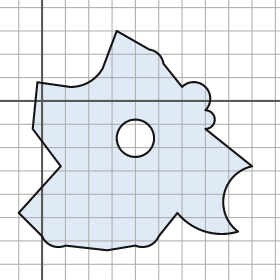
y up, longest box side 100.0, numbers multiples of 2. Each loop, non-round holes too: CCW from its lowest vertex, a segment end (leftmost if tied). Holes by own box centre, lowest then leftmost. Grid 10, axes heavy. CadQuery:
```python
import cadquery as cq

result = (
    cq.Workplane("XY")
    .moveTo(28.0, -64.0)
    .lineTo(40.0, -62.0)
    .threePointArc((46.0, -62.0), (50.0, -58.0))
    .lineTo(58.0, -48.0)
    .threePointArc((70.0, -56.0), (84.0, -56.0))
    .threePointArc((78.0, -40.0), (90.0, -28.0))
    .lineTo(70.0, -12.0)
    .threePointArc((74.0, -8.0), (70.0, -4.0))
    .threePointArc((70.0, 6.0), (60.0, 6.0))
    .lineTo(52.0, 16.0)
    .threePointArc((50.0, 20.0), (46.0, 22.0))
    .lineTo(32.0, 30.0)
    .lineTo(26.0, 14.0)
    .threePointArc((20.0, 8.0), (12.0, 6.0))
    .lineTo(-2.0, 8.0)
    .lineTo(-4.0, -12.0)
    .lineTo(8.0, -28.0)
    .lineTo(-10.0, -48.0)
    .lineTo(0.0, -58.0)
    .threePointArc((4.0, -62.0), (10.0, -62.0))
    .close()
    .moveTo(40.0, -16.0)
    .circle(8.0)
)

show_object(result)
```